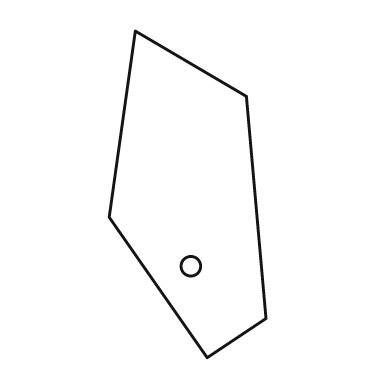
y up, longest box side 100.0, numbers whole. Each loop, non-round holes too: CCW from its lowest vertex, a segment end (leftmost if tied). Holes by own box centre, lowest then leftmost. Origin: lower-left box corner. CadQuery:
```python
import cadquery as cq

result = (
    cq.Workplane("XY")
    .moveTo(30.0, 0.0)
    .lineTo(48.0, 12.0)
    .lineTo(42.0, 80.0)
    .lineTo(8.0, 100.0)
    .lineTo(0.0, 43.0)
    .close()
    .moveTo(25.0, 28.0)
    .circle(3.0)
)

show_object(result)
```